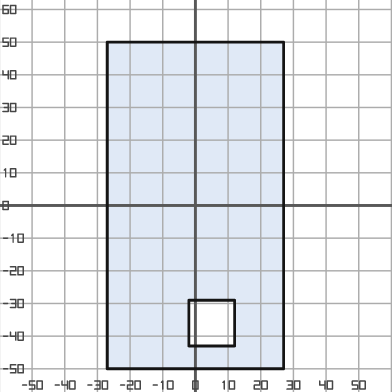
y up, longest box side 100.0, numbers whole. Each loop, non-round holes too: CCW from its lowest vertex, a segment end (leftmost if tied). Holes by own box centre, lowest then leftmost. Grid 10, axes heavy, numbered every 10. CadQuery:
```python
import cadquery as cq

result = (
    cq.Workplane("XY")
    .moveTo(-27.0, -50.0)
    .lineTo(27.0, -50.0)
    .lineTo(27.0, 50.0)
    .lineTo(-27.0, 50.0)
    .close()
    .moveTo(-2.0, -43.0)
    .lineTo(12.0, -43.0)
    .lineTo(12.0, -29.0)
    .lineTo(-2.0, -29.0)
    .close()
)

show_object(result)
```